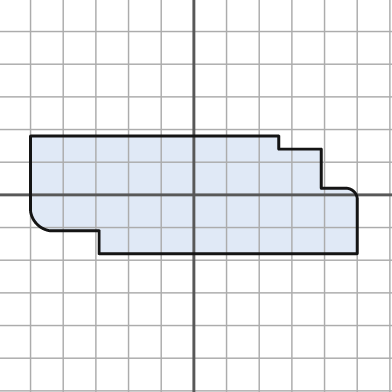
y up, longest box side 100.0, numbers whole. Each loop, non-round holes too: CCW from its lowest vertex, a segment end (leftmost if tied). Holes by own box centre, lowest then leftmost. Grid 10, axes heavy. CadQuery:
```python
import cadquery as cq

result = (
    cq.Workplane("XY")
    .moveTo(-29.0, -18.0)
    .lineTo(50.0, -18.0)
    .lineTo(50.0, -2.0)
    .threePointArc((49.0, 1.0), (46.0, 2.0))
    .lineTo(39.0, 2.0)
    .lineTo(39.0, 14.0)
    .lineTo(26.0, 14.0)
    .lineTo(26.0, 18.0)
    .lineTo(-50.0, 18.0)
    .lineTo(-50.0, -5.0)
    .threePointArc((-48.0, -9.0), (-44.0, -11.0))
    .lineTo(-29.0, -11.0)
    .close()
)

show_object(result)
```